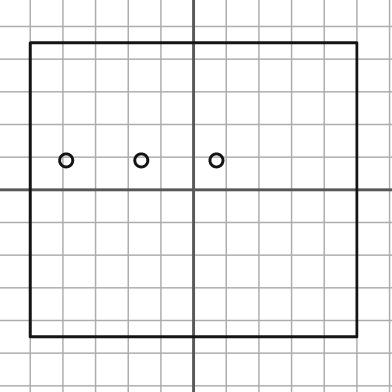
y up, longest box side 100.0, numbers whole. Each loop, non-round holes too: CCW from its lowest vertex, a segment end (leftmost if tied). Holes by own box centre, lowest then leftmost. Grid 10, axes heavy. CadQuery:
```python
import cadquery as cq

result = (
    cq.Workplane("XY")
    .moveTo(-50.0, -45.0)
    .lineTo(50.0, -45.0)
    .lineTo(50.0, 45.0)
    .lineTo(-50.0, 45.0)
    .close()
    .moveTo(-39.0, 9.0)
    .circle(2.0)
    .moveTo(-16.0, 9.0)
    .circle(2.0)
    .moveTo(7.0, 9.0)
    .circle(2.0)
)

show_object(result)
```